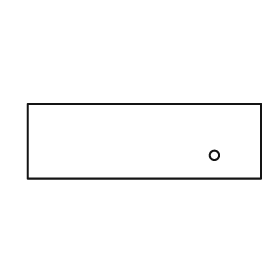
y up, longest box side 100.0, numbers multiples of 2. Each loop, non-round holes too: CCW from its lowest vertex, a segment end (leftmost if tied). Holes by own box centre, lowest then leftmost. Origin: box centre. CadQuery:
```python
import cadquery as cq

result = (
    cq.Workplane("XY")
    .moveTo(-50.0, -16.0)
    .lineTo(50.0, -16.0)
    .lineTo(50.0, 16.0)
    .lineTo(-50.0, 16.0)
    .close()
    .moveTo(30.0, -6.0)
    .circle(2.0)
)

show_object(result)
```